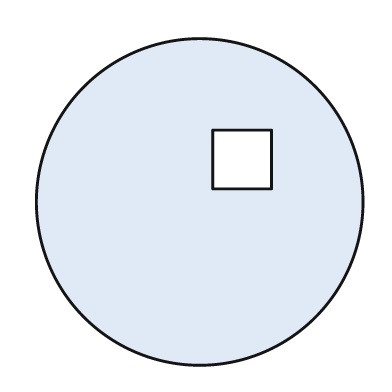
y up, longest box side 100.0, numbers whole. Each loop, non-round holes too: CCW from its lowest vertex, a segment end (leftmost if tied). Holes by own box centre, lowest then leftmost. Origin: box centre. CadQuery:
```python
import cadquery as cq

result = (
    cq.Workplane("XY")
    .moveTo(0.0, 0.0)
    .circle(50.0)
    .moveTo(4.0, 4.0)
    .lineTo(22.0, 4.0)
    .lineTo(22.0, 22.0)
    .lineTo(4.0, 22.0)
    .close()
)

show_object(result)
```